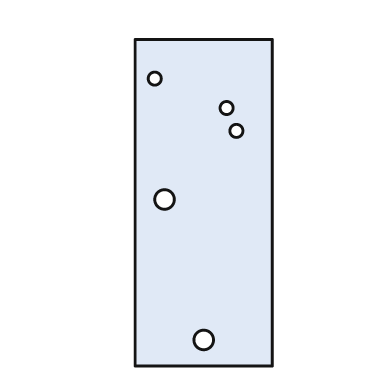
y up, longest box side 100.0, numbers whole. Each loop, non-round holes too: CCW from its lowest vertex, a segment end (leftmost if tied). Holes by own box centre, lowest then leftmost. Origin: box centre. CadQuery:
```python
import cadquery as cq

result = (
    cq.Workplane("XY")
    .moveTo(-21.0, -50.0)
    .lineTo(21.0, -50.0)
    .lineTo(21.0, 50.0)
    .lineTo(-21.0, 50.0)
    .close()
    .moveTo(0.0, -42.0)
    .circle(3.0)
    .moveTo(-12.0, 1.0)
    .circle(3.0)
    .moveTo(10.0, 22.0)
    .circle(2.0)
    .moveTo(7.0, 29.0)
    .circle(2.0)
    .moveTo(-15.0, 38.0)
    .circle(2.0)
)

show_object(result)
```